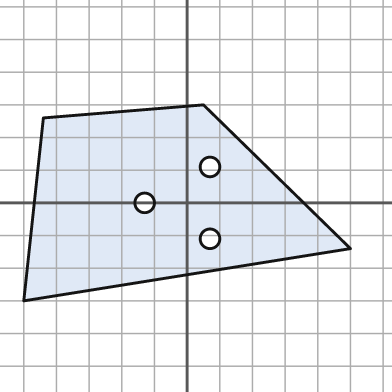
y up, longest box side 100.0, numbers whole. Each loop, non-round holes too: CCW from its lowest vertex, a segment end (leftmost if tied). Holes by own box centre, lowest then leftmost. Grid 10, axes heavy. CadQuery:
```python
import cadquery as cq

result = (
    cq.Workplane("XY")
    .moveTo(-50.0, -30.0)
    .lineTo(50.0, -14.0)
    .lineTo(5.0, 30.0)
    .lineTo(-44.0, 26.0)
    .close()
    .moveTo(7.0, -11.0)
    .circle(3.0)
    .moveTo(-13.0, 0.0)
    .circle(3.0)
    .moveTo(7.0, 11.0)
    .circle(3.0)
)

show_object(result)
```